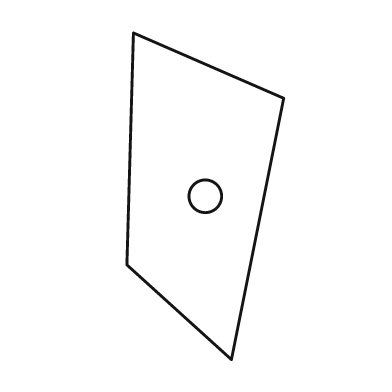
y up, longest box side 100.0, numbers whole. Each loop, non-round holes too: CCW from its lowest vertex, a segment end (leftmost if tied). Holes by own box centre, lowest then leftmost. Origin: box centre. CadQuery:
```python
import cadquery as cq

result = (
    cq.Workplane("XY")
    .moveTo(8.0, -50.0)
    .lineTo(24.0, 30.0)
    .lineTo(-22.0, 50.0)
    .lineTo(-24.0, -21.0)
    .close()
    .moveTo(0.0, 0.0)
    .circle(5.0)
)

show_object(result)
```